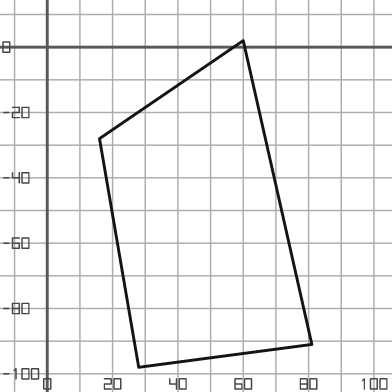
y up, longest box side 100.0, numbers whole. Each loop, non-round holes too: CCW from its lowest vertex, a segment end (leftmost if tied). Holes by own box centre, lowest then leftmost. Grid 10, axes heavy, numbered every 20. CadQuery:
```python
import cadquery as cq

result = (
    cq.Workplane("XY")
    .moveTo(28.0, -98.0)
    .lineTo(81.0, -91.0)
    .lineTo(60.0, 2.0)
    .lineTo(16.0, -28.0)
    .close()
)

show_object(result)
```